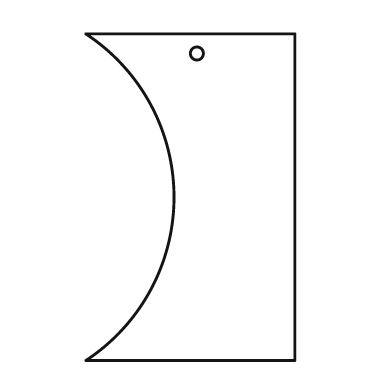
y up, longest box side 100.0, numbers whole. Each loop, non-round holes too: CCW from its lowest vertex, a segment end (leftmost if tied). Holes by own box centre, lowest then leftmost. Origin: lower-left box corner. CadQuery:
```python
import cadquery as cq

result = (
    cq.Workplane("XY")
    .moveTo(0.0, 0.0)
    .lineTo(64.0, 0.0)
    .lineTo(64.0, 100.0)
    .lineTo(0.0, 100.0)
    .threePointArc((27.0, 50.0), (0.0, 0.0))
    .close()
    .moveTo(34.0, 94.0)
    .circle(2.0)
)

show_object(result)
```